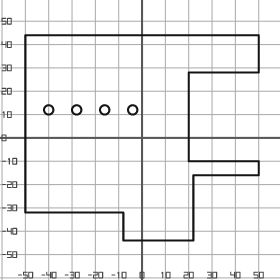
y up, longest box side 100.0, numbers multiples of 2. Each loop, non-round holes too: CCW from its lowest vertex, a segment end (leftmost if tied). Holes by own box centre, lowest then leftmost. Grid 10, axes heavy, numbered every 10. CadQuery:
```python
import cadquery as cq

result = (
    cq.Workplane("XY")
    .moveTo(-8.0, -44.0)
    .lineTo(22.0, -44.0)
    .lineTo(22.0, -16.0)
    .lineTo(50.0, -16.0)
    .lineTo(50.0, -10.0)
    .lineTo(20.0, -10.0)
    .lineTo(20.0, 28.0)
    .lineTo(50.0, 28.0)
    .lineTo(50.0, 44.0)
    .lineTo(-50.0, 44.0)
    .lineTo(-50.0, -32.0)
    .lineTo(-8.0, -32.0)
    .close()
    .moveTo(-40.0, 12.0)
    .circle(2.0)
    .moveTo(-28.0, 12.0)
    .circle(2.0)
    .moveTo(-16.0, 12.0)
    .circle(2.0)
    .moveTo(-4.0, 12.0)
    .circle(2.0)
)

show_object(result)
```